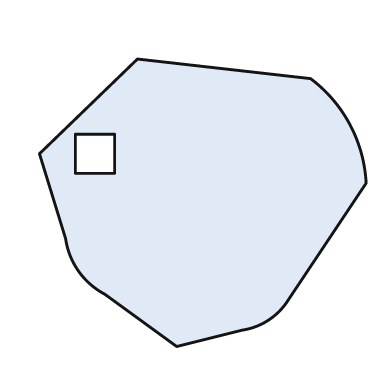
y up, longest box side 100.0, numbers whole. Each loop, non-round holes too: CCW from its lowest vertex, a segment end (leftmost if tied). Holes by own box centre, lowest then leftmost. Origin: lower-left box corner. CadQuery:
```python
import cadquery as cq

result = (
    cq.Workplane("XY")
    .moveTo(42.0, 0.0)
    .lineTo(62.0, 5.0)
    .threePointArc((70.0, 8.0), (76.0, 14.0))
    .lineTo(100.0, 50.0)
    .threePointArc((95.0, 68.0), (83.0, 82.0))
    .lineTo(30.0, 88.0)
    .lineTo(0.0, 59.0)
    .lineTo(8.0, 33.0)
    .threePointArc((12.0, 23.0), (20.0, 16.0))
    .close()
    .moveTo(11.0, 53.0)
    .lineTo(23.0, 53.0)
    .lineTo(23.0, 65.0)
    .lineTo(11.0, 65.0)
    .close()
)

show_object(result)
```